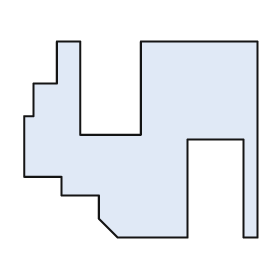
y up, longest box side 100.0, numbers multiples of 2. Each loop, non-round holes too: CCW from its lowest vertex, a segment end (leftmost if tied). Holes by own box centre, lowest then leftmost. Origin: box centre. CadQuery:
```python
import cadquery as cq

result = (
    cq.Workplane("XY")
    .moveTo(-10.0, -42.0)
    .lineTo(20.0, -42.0)
    .lineTo(20.0, 0.0)
    .lineTo(44.0, 0.0)
    .lineTo(44.0, -42.0)
    .lineTo(50.0, -42.0)
    .lineTo(50.0, 42.0)
    .lineTo(0.0, 42.0)
    .lineTo(0.0, 2.0)
    .lineTo(-26.0, 2.0)
    .lineTo(-26.0, 42.0)
    .lineTo(-36.0, 42.0)
    .lineTo(-36.0, 24.0)
    .lineTo(-46.0, 24.0)
    .lineTo(-46.0, 10.0)
    .lineTo(-50.0, 10.0)
    .lineTo(-50.0, -16.0)
    .lineTo(-34.0, -16.0)
    .lineTo(-34.0, -24.0)
    .lineTo(-18.0, -24.0)
    .lineTo(-18.0, -34.0)
    .close()
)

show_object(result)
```